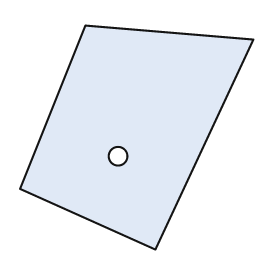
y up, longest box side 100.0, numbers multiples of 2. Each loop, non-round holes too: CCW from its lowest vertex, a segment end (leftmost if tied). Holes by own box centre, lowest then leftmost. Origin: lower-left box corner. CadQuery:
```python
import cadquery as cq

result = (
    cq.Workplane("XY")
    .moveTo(58.0, 0.0)
    .lineTo(100.0, 90.0)
    .lineTo(28.0, 96.0)
    .lineTo(0.0, 26.0)
    .close()
    .moveTo(42.0, 40.0)
    .circle(4.0)
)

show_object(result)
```